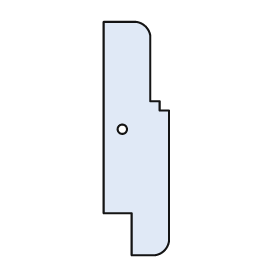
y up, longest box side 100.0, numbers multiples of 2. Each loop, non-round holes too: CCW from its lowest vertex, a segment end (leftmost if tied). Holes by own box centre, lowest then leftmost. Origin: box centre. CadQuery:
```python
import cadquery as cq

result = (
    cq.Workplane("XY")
    .moveTo(-2.0, -50.0)
    .lineTo(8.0, -50.0)
    .threePointArc((12.0, -48.0), (14.0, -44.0))
    .lineTo(14.0, 12.0)
    .lineTo(10.0, 12.0)
    .lineTo(10.0, 16.0)
    .lineTo(6.0, 16.0)
    .lineTo(6.0, 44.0)
    .threePointArc((4.0, 48.0), (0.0, 50.0))
    .lineTo(-14.0, 50.0)
    .lineTo(-14.0, -32.0)
    .lineTo(-2.0, -32.0)
    .close()
    .moveTo(-6.0, 4.0)
    .circle(2.0)
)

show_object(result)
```